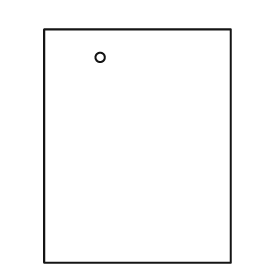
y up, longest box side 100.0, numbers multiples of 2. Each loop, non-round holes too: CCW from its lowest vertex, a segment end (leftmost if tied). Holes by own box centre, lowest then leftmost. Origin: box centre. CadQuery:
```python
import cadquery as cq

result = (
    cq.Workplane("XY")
    .moveTo(-40.0, -50.0)
    .lineTo(40.0, -50.0)
    .lineTo(40.0, 50.0)
    .lineTo(-40.0, 50.0)
    .close()
    .moveTo(-16.0, 38.0)
    .circle(2.0)
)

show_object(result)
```